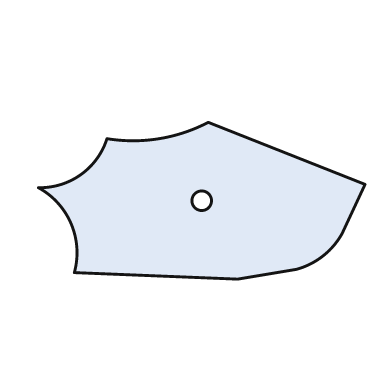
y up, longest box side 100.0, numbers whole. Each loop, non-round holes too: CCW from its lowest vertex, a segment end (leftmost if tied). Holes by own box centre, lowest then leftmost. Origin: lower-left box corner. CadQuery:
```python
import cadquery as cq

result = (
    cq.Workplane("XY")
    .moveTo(61.0, 0.0)
    .lineTo(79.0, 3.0)
    .threePointArc((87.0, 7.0), (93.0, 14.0))
    .lineTo(100.0, 29.0)
    .lineTo(52.0, 48.0)
    .threePointArc((37.0, 43.0), (21.0, 43.0))
    .threePointArc((13.0, 32.0), (0.0, 28.0))
    .threePointArc((10.0, 17.0), (11.0, 2.0))
    .close()
    .moveTo(50.0, 24.0)
    .circle(3.0)
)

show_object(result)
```